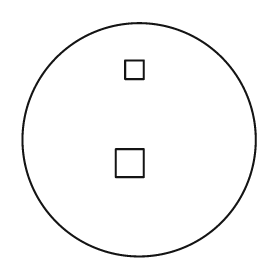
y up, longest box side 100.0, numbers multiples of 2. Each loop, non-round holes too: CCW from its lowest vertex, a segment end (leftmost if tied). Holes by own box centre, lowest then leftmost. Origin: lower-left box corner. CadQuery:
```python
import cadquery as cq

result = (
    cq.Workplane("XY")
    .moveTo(50.0, 50.0)
    .circle(50.0)
    .moveTo(40.0, 34.0)
    .lineTo(52.0, 34.0)
    .lineTo(52.0, 46.0)
    .lineTo(40.0, 46.0)
    .close()
    .moveTo(44.0, 76.0)
    .lineTo(52.0, 76.0)
    .lineTo(52.0, 84.0)
    .lineTo(44.0, 84.0)
    .close()
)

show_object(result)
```